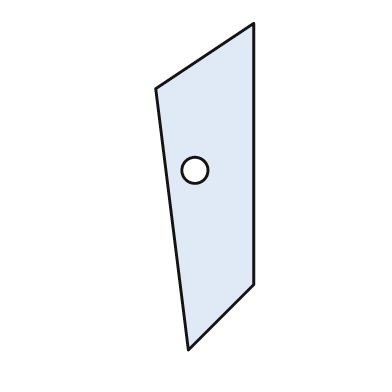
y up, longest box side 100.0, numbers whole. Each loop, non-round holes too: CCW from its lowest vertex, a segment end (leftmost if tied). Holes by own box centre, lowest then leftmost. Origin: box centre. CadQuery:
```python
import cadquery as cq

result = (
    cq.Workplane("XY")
    .moveTo(-5.0, -50.0)
    .lineTo(15.0, -30.0)
    .lineTo(15.0, 50.0)
    .lineTo(-15.0, 30.0)
    .close()
    .moveTo(-3.0, 5.0)
    .circle(4.0)
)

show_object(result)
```